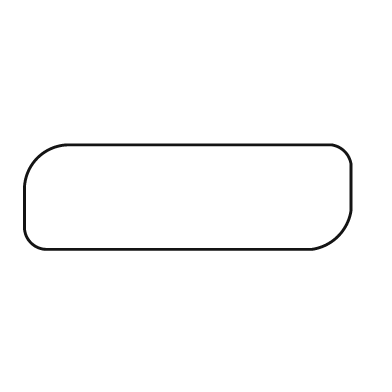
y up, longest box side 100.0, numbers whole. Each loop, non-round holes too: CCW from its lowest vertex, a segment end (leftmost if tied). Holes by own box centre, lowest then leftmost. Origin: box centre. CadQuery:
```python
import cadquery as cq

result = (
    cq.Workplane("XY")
    .moveTo(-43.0, -16.0)
    .lineTo(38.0, -16.0)
    .threePointArc((46.0, -12.0), (50.0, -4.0))
    .lineTo(50.0, 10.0)
    .threePointArc((48.0, 14.0), (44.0, 16.0))
    .lineTo(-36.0, 16.0)
    .threePointArc((-46.0, 12.0), (-50.0, 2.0))
    .lineTo(-50.0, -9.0)
    .threePointArc((-48.0, -14.0), (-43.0, -16.0))
    .close()
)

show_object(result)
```